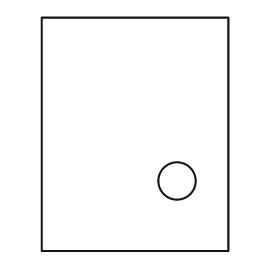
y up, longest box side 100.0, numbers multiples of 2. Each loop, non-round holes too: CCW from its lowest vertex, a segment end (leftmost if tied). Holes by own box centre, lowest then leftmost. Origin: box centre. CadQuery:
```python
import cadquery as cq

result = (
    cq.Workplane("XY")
    .moveTo(-40.0, -50.0)
    .lineTo(40.0, -50.0)
    .lineTo(40.0, 50.0)
    .lineTo(-40.0, 50.0)
    .close()
    .moveTo(18.0, -20.0)
    .circle(8.0)
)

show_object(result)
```